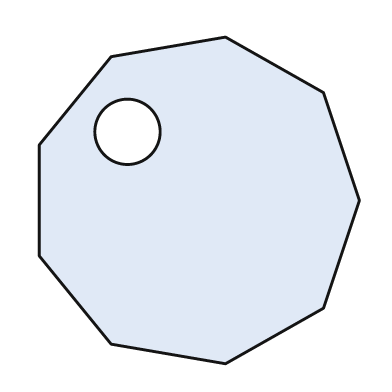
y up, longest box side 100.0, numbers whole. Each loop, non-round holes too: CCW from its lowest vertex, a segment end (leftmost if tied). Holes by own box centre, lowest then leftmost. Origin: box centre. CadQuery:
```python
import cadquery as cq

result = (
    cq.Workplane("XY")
    .moveTo(8.0, -50.0)
    .lineTo(38.0, -33.0)
    .lineTo(49.0, 0.0)
    .lineTo(38.0, 33.0)
    .lineTo(8.0, 50.0)
    .lineTo(-27.0, 44.0)
    .lineTo(-49.0, 17.0)
    .lineTo(-49.0, -17.0)
    .lineTo(-27.0, -44.0)
    .close()
    .moveTo(-22.0, 21.0)
    .circle(10.0)
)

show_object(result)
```